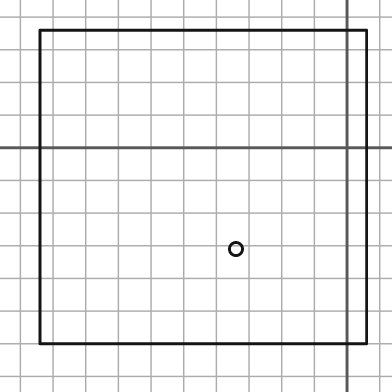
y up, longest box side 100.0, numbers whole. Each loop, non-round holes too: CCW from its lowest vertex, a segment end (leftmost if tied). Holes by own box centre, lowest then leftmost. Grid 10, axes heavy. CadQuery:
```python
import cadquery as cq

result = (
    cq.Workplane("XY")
    .moveTo(-94.0, -60.0)
    .lineTo(6.0, -60.0)
    .lineTo(6.0, 36.0)
    .lineTo(-94.0, 36.0)
    .close()
    .moveTo(-34.0, -31.0)
    .circle(2.0)
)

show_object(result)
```